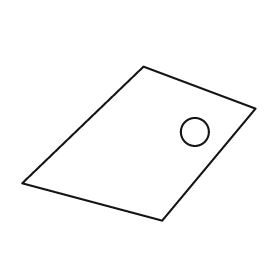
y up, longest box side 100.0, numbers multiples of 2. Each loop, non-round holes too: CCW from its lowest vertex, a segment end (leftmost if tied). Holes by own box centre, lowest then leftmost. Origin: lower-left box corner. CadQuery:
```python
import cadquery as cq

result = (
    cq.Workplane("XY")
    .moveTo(60.0, 0.0)
    .lineTo(100.0, 48.0)
    .lineTo(52.0, 66.0)
    .lineTo(0.0, 16.0)
    .close()
    .moveTo(74.0, 38.0)
    .circle(6.0)
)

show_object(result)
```